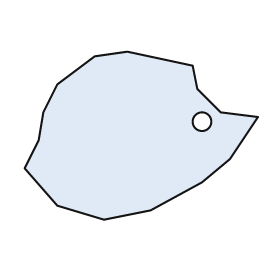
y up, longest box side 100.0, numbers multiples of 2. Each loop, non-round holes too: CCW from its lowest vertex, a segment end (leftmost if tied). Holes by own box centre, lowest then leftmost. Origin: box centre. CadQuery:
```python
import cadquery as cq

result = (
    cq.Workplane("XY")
    .moveTo(-16.0, -36.0)
    .lineTo(4.0, -32.0)
    .lineTo(26.0, -20.0)
    .lineTo(38.0, -10.0)
    .lineTo(50.0, 8.0)
    .lineTo(34.0, 10.0)
    .lineTo(24.0, 20.0)
    .lineTo(22.0, 30.0)
    .lineTo(-6.0, 36.0)
    .lineTo(-20.0, 34.0)
    .lineTo(-36.0, 22.0)
    .lineTo(-42.0, 10.0)
    .lineTo(-44.0, -2.0)
    .lineTo(-50.0, -14.0)
    .lineTo(-36.0, -30.0)
    .close()
    .moveTo(26.0, 6.0)
    .circle(4.0)
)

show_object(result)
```